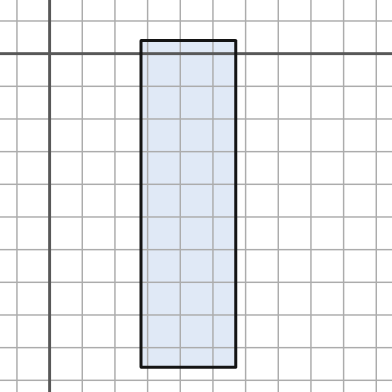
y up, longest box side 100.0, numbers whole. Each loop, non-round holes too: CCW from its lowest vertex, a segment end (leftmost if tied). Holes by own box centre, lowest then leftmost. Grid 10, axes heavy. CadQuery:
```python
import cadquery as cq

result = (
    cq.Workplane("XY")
    .moveTo(28.0, -96.0)
    .lineTo(57.0, -96.0)
    .lineTo(57.0, 4.0)
    .lineTo(28.0, 4.0)
    .close()
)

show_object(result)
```